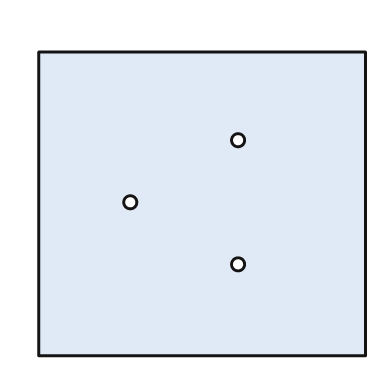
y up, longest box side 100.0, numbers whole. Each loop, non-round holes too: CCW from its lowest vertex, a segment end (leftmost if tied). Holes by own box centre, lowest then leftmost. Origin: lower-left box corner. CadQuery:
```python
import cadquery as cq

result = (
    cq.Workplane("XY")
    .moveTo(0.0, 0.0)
    .lineTo(100.0, 0.0)
    .lineTo(100.0, 93.0)
    .lineTo(0.0, 93.0)
    .close()
    .moveTo(61.0, 28.0)
    .circle(2.0)
    .moveTo(28.0, 47.0)
    .circle(2.0)
    .moveTo(61.0, 66.0)
    .circle(2.0)
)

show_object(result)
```